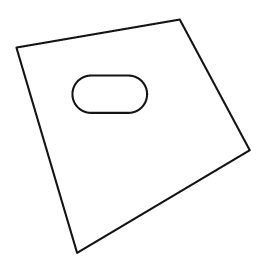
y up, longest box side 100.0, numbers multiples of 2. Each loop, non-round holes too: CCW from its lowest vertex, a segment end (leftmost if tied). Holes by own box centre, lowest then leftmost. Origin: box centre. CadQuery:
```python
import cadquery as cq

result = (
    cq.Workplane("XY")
    .moveTo(-24.0, -50.0)
    .lineTo(50.0, -6.0)
    .lineTo(20.0, 50.0)
    .lineTo(-50.0, 38.0)
    .close()
    .moveTo(-18.0, 10.0)
    .lineTo(-2.0, 10.0)
    .threePointArc((6.0, 18.0), (-2.0, 26.0))
    .lineTo(-18.0, 26.0)
    .threePointArc((-26.0, 18.0), (-18.0, 10.0))
    .close()
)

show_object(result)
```